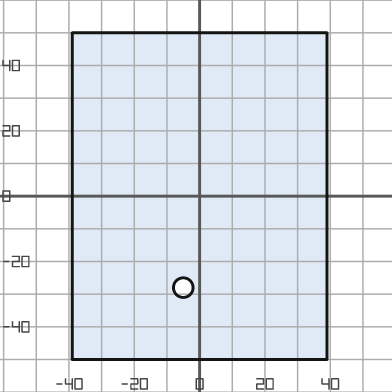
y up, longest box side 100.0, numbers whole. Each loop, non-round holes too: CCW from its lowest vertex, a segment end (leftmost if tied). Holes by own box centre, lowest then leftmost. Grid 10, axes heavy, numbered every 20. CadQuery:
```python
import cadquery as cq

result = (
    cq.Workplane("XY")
    .moveTo(-39.0, -50.0)
    .lineTo(39.0, -50.0)
    .lineTo(39.0, 50.0)
    .lineTo(-39.0, 50.0)
    .close()
    .moveTo(-5.0, -28.0)
    .circle(3.0)
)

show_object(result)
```